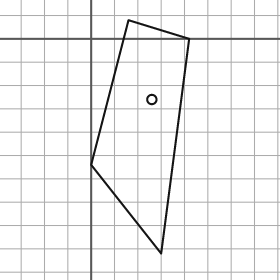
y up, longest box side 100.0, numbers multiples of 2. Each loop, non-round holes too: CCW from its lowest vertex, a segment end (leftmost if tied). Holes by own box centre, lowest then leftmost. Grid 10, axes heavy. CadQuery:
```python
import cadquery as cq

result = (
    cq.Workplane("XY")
    .moveTo(30.0, -92.0)
    .lineTo(42.0, 0.0)
    .lineTo(16.0, 8.0)
    .lineTo(0.0, -54.0)
    .close()
    .moveTo(26.0, -26.0)
    .circle(2.0)
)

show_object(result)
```